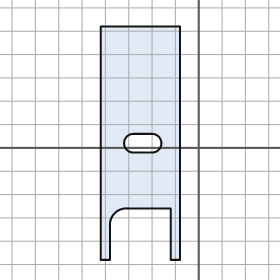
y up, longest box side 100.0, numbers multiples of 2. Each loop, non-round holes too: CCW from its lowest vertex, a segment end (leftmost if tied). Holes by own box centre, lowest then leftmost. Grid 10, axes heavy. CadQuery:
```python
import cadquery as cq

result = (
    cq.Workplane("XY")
    .moveTo(-42.0, -48.0)
    .lineTo(-38.0, -48.0)
    .lineTo(-38.0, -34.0)
    .threePointArc((-36.0, -28.0), (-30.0, -26.0))
    .lineTo(-12.0, -26.0)
    .lineTo(-12.0, -48.0)
    .lineTo(-8.0, -48.0)
    .lineTo(-8.0, 52.0)
    .lineTo(-42.0, 52.0)
    .close()
    .moveTo(-28.0, -2.0)
    .lineTo(-20.0, -2.0)
    .threePointArc((-16.0, 2.0), (-20.0, 6.0))
    .lineTo(-28.0, 6.0)
    .threePointArc((-32.0, 2.0), (-28.0, -2.0))
    .close()
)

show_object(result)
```